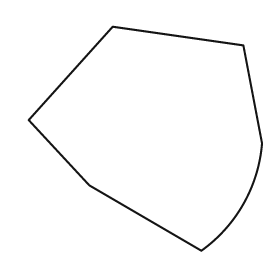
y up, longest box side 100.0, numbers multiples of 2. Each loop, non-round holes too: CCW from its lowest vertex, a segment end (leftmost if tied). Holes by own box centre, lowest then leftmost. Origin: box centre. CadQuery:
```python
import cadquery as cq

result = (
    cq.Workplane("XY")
    .moveTo(24.0, -48.0)
    .threePointArc((42.0, -28.0), (50.0, -2.0))
    .lineTo(42.0, 40.0)
    .lineTo(-14.0, 48.0)
    .lineTo(-50.0, 8.0)
    .lineTo(-24.0, -20.0)
    .close()
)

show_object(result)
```